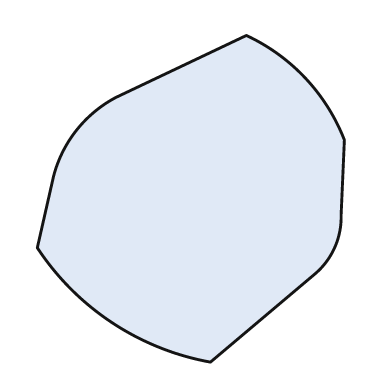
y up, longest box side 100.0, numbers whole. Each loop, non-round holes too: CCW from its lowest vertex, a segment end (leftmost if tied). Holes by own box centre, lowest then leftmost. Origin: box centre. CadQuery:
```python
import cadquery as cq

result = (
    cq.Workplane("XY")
    .moveTo(6.0, -50.0)
    .lineTo(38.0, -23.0)
    .threePointArc((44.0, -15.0), (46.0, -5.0))
    .lineTo(47.0, 18.0)
    .threePointArc((35.0, 37.0), (17.0, 50.0))
    .lineTo(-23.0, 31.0)
    .threePointArc((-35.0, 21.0), (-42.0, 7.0))
    .lineTo(-47.0, -15.0)
    .threePointArc((-24.0, -38.0), (6.0, -50.0))
    .close()
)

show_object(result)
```